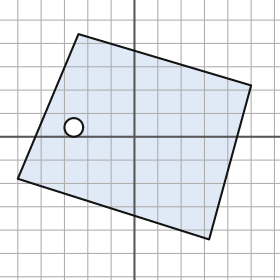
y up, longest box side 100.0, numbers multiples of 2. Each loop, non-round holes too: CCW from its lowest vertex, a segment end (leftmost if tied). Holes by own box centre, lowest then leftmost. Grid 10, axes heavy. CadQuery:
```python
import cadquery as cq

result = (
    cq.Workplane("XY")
    .moveTo(32.0, -44.0)
    .lineTo(50.0, 22.0)
    .lineTo(-24.0, 44.0)
    .lineTo(-50.0, -18.0)
    .close()
    .moveTo(-26.0, 4.0)
    .circle(4.0)
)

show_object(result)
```